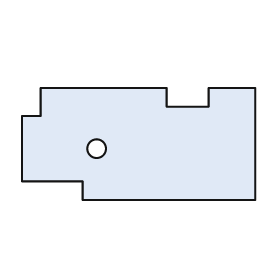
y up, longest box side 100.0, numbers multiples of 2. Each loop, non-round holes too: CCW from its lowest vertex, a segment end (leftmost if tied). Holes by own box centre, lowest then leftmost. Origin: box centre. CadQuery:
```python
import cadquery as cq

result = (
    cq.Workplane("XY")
    .moveTo(-24.0, -24.0)
    .lineTo(50.0, -24.0)
    .lineTo(50.0, 24.0)
    .lineTo(30.0, 24.0)
    .lineTo(30.0, 16.0)
    .lineTo(12.0, 16.0)
    .lineTo(12.0, 24.0)
    .lineTo(-42.0, 24.0)
    .lineTo(-42.0, 12.0)
    .lineTo(-50.0, 12.0)
    .lineTo(-50.0, -16.0)
    .lineTo(-24.0, -16.0)
    .close()
    .moveTo(-18.0, -2.0)
    .circle(4.0)
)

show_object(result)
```